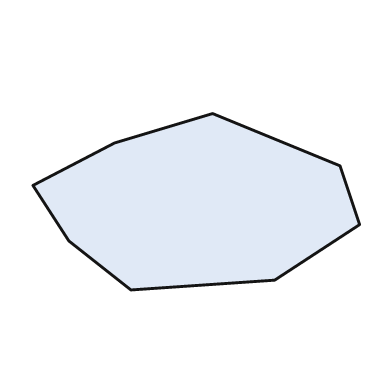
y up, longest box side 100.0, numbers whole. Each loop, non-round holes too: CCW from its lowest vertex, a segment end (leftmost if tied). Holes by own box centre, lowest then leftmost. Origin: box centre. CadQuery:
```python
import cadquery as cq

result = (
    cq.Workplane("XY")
    .moveTo(-20.0, -27.0)
    .lineTo(24.0, -24.0)
    .lineTo(50.0, -7.0)
    .lineTo(44.0, 11.0)
    .lineTo(5.0, 27.0)
    .lineTo(-25.0, 18.0)
    .lineTo(-50.0, 5.0)
    .lineTo(-39.0, -12.0)
    .close()
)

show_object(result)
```